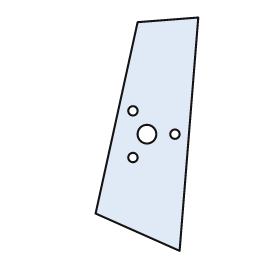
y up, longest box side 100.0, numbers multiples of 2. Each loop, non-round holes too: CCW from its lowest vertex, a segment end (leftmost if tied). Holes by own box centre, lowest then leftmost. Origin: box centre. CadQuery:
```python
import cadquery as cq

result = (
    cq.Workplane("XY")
    .moveTo(14.0, -50.0)
    .lineTo(22.0, 50.0)
    .lineTo(-4.0, 48.0)
    .lineTo(-22.0, -34.0)
    .close()
    .moveTo(-6.0, -10.0)
    .circle(2.0)
    .moveTo(0.0, 0.0)
    .circle(4.0)
    .moveTo(12.0, 0.0)
    .circle(2.0)
    .moveTo(-6.0, 10.0)
    .circle(2.0)
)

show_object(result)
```